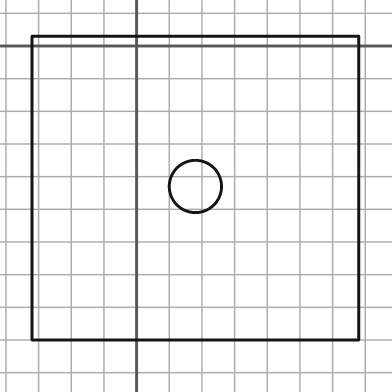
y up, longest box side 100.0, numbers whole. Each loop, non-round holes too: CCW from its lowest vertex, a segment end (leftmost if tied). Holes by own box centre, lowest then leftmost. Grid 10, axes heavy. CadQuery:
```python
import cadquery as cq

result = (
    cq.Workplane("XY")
    .moveTo(-32.0, -90.0)
    .lineTo(68.0, -90.0)
    .lineTo(68.0, 3.0)
    .lineTo(-32.0, 3.0)
    .close()
    .moveTo(18.0, -43.0)
    .circle(8.0)
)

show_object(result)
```